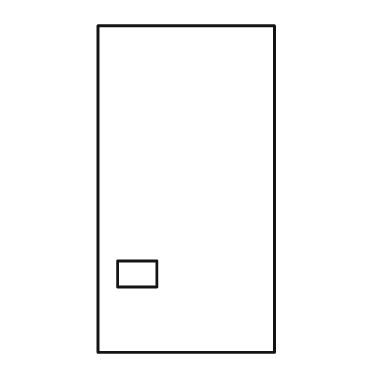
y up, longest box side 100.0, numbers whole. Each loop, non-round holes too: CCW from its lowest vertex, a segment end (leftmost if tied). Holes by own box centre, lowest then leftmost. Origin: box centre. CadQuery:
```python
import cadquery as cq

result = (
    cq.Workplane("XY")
    .moveTo(-27.0, -50.0)
    .lineTo(27.0, -50.0)
    .lineTo(27.0, 50.0)
    .lineTo(-27.0, 50.0)
    .close()
    .moveTo(-21.0, -30.0)
    .lineTo(-9.0, -30.0)
    .lineTo(-9.0, -22.0)
    .lineTo(-21.0, -22.0)
    .close()
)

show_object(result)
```